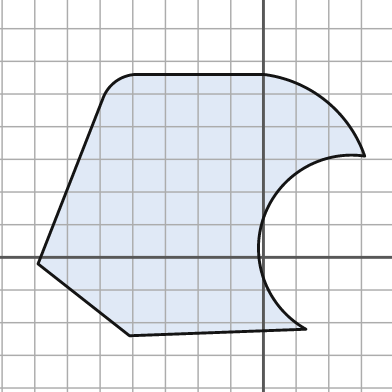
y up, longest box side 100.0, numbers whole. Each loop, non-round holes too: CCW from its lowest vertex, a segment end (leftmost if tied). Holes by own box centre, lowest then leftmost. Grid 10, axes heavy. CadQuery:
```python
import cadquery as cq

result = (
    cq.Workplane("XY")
    .moveTo(-41.0, -24.0)
    .lineTo(13.0, -22.0)
    .threePointArc((0.0, 12.0), (31.0, 31.0))
    .threePointArc((19.0, 48.0), (0.0, 56.0))
    .lineTo(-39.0, 56.0)
    .threePointArc((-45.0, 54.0), (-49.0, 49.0))
    .lineTo(-69.0, -2.0)
    .close()
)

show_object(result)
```